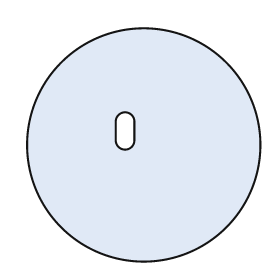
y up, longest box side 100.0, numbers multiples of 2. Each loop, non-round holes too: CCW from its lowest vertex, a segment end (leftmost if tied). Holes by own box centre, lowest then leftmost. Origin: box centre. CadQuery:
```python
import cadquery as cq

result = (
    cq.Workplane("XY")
    .moveTo(0.0, 0.0)
    .circle(50.0)
    .moveTo(-12.0, 2.0)
    .threePointArc((-8.0, -2.0), (-4.0, 2.0))
    .lineTo(-4.0, 10.0)
    .threePointArc((-8.0, 14.0), (-12.0, 10.0))
    .close()
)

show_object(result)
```